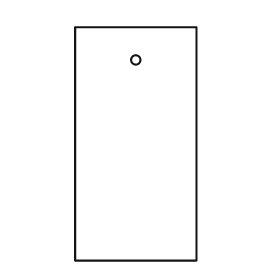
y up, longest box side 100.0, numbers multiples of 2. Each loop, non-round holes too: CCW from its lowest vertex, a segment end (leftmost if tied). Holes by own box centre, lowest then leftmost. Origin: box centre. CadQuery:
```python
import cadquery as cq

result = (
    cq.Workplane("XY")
    .moveTo(-26.0, -50.0)
    .lineTo(26.0, -50.0)
    .lineTo(26.0, 50.0)
    .lineTo(-26.0, 50.0)
    .close()
    .moveTo(0.0, 36.0)
    .circle(2.0)
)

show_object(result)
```